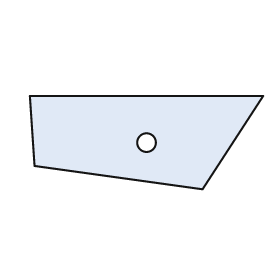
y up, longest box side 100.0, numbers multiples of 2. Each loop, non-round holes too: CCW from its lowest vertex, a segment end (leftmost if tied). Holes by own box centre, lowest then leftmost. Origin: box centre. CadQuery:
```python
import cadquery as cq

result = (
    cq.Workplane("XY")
    .moveTo(24.0, -20.0)
    .lineTo(50.0, 20.0)
    .lineTo(-50.0, 20.0)
    .lineTo(-48.0, -10.0)
    .close()
    .moveTo(0.0, 0.0)
    .circle(4.0)
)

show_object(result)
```